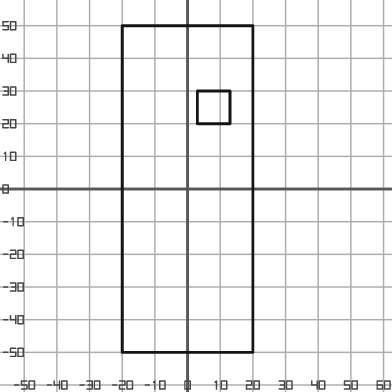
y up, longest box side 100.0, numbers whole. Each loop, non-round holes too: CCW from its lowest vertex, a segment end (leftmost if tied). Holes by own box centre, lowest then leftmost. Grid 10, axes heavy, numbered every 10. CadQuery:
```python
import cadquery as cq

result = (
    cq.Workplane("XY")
    .moveTo(-20.0, -50.0)
    .lineTo(20.0, -50.0)
    .lineTo(20.0, 50.0)
    .lineTo(-20.0, 50.0)
    .close()
    .moveTo(3.0, 20.0)
    .lineTo(13.0, 20.0)
    .lineTo(13.0, 30.0)
    .lineTo(3.0, 30.0)
    .close()
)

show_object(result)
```